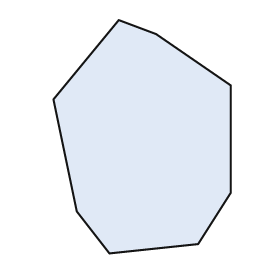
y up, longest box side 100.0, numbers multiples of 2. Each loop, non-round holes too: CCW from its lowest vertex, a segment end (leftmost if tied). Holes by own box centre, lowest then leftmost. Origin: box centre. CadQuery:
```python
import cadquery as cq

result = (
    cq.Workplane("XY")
    .moveTo(-14.0, -50.0)
    .lineTo(24.0, -46.0)
    .lineTo(38.0, -24.0)
    .lineTo(38.0, 22.0)
    .lineTo(6.0, 44.0)
    .lineTo(-10.0, 50.0)
    .lineTo(-38.0, 16.0)
    .lineTo(-28.0, -32.0)
    .close()
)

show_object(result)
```